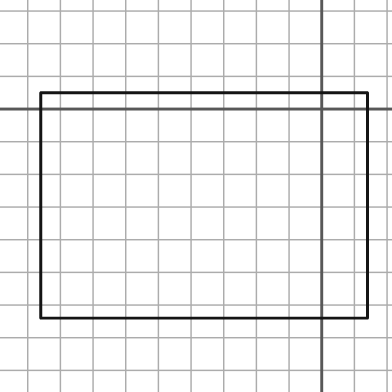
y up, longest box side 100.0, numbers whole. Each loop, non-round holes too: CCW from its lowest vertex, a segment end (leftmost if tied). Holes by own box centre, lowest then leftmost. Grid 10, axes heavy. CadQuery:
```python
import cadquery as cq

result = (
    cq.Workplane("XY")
    .moveTo(-86.0, -64.0)
    .lineTo(14.0, -64.0)
    .lineTo(14.0, 5.0)
    .lineTo(-86.0, 5.0)
    .close()
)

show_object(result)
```